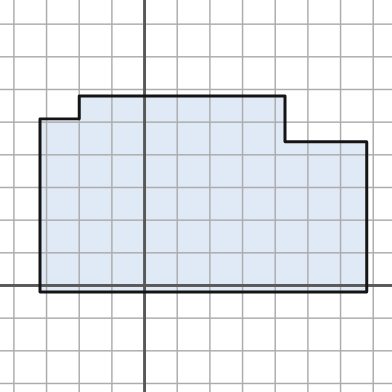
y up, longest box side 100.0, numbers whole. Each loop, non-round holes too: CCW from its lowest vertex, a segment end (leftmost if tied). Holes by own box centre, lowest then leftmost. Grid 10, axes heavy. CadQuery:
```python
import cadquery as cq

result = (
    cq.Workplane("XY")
    .moveTo(-32.0, -2.0)
    .lineTo(68.0, -2.0)
    .lineTo(68.0, 44.0)
    .lineTo(43.0, 44.0)
    .lineTo(43.0, 58.0)
    .lineTo(-20.0, 58.0)
    .lineTo(-20.0, 51.0)
    .lineTo(-32.0, 51.0)
    .close()
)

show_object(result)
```